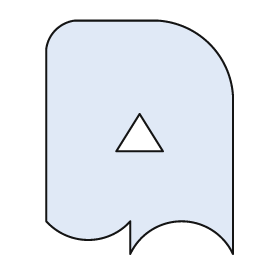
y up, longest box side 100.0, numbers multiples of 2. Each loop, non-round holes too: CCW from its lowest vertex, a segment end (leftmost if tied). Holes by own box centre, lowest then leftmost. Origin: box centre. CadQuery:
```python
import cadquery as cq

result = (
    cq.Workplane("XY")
    .moveTo(-4.0, -50.0)
    .threePointArc((18.0, -36.0), (40.0, -50.0))
    .lineTo(40.0, 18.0)
    .threePointArc((30.0, 40.0), (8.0, 50.0))
    .lineTo(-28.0, 50.0)
    .threePointArc((-36.0, 46.0), (-40.0, 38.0))
    .lineTo(-40.0, -36.0)
    .threePointArc((-22.0, -44.0), (-4.0, -36.0))
    .close()
    .moveTo(-10.0, -6.0)
    .lineTo(10.0, -6.0)
    .lineTo(0.0, 10.0)
    .close()
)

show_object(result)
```